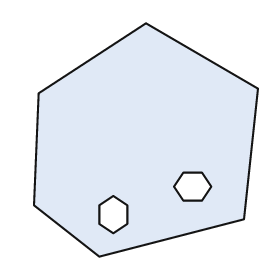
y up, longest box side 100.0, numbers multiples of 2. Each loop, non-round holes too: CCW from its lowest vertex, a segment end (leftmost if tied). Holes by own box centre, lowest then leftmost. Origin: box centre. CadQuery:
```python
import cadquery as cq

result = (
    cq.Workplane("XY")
    .moveTo(-20.0, -50.0)
    .lineTo(42.0, -34.0)
    .lineTo(48.0, 22.0)
    .lineTo(0.0, 50.0)
    .lineTo(-46.0, 20.0)
    .lineTo(-48.0, -28.0)
    .close()
    .moveTo(-14.0, -40.0)
    .lineTo(-8.0, -36.0)
    .lineTo(-8.0, -28.0)
    .lineTo(-14.0, -24.0)
    .lineTo(-20.0, -28.0)
    .lineTo(-20.0, -36.0)
    .close()
    .moveTo(16.0, -26.0)
    .lineTo(24.0, -26.0)
    .lineTo(28.0, -20.0)
    .lineTo(24.0, -14.0)
    .lineTo(16.0, -14.0)
    .lineTo(12.0, -20.0)
    .close()
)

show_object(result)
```